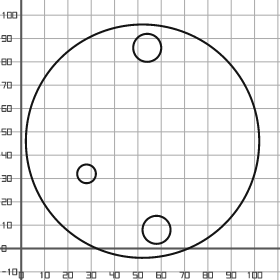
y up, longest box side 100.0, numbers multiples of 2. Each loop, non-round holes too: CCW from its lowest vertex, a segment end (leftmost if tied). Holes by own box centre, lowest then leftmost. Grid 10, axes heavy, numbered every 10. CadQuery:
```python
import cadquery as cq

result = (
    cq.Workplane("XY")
    .moveTo(52.0, 46.0)
    .circle(50.0)
    .moveTo(58.0, 8.0)
    .circle(6.0)
    .moveTo(28.0, 32.0)
    .circle(4.0)
    .moveTo(54.0, 86.0)
    .circle(6.0)
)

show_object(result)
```